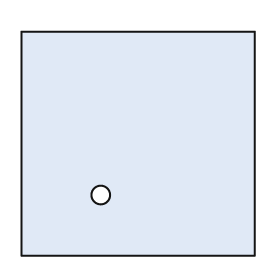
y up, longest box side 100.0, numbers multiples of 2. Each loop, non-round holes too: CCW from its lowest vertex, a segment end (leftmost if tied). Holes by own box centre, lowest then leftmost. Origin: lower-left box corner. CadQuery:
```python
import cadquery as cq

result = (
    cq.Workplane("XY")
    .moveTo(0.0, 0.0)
    .lineTo(100.0, 0.0)
    .lineTo(100.0, 96.0)
    .lineTo(0.0, 96.0)
    .close()
    .moveTo(34.0, 26.0)
    .circle(4.0)
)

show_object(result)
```